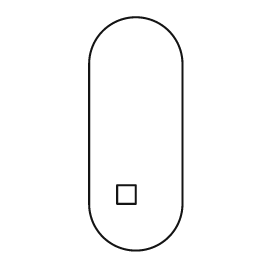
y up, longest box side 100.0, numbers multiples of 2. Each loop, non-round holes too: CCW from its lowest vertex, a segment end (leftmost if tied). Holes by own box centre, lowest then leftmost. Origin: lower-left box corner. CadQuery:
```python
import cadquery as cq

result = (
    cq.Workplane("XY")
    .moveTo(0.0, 20.0)
    .threePointArc((20.0, 0.0), (40.0, 20.0))
    .lineTo(40.0, 80.0)
    .threePointArc((20.0, 100.0), (0.0, 80.0))
    .close()
    .moveTo(12.0, 20.0)
    .lineTo(20.0, 20.0)
    .lineTo(20.0, 28.0)
    .lineTo(12.0, 28.0)
    .close()
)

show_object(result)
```